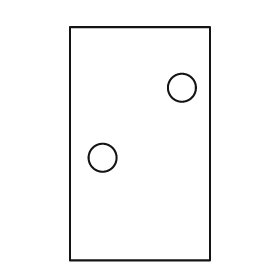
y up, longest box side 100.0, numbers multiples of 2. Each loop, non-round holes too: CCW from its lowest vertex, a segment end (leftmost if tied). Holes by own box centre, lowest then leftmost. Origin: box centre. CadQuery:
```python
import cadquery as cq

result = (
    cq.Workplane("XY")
    .moveTo(-30.0, -50.0)
    .lineTo(30.0, -50.0)
    .lineTo(30.0, 50.0)
    .lineTo(-30.0, 50.0)
    .close()
    .moveTo(-16.0, -6.0)
    .circle(6.0)
    .moveTo(18.0, 24.0)
    .circle(6.0)
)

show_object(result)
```